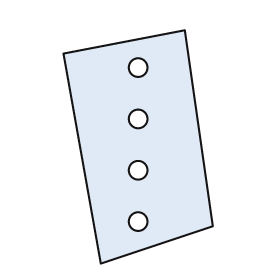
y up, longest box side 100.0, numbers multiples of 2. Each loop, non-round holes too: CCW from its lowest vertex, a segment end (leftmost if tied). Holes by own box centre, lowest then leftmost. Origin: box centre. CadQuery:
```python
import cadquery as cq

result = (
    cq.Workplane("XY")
    .moveTo(-16.0, -50.0)
    .lineTo(32.0, -34.0)
    .lineTo(20.0, 50.0)
    .lineTo(-32.0, 40.0)
    .close()
    .moveTo(0.0, -32.0)
    .circle(4.0)
    .moveTo(0.0, -10.0)
    .circle(4.0)
    .moveTo(0.0, 12.0)
    .circle(4.0)
    .moveTo(0.0, 34.0)
    .circle(4.0)
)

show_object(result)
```